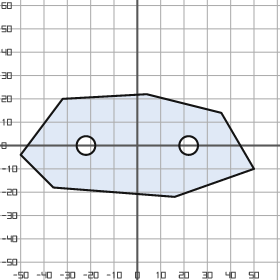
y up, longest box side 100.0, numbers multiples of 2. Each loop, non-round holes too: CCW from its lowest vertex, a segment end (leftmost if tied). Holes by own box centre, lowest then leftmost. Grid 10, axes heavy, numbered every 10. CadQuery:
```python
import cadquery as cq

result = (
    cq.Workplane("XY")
    .moveTo(16.0, -22.0)
    .lineTo(50.0, -10.0)
    .lineTo(36.0, 14.0)
    .lineTo(4.0, 22.0)
    .lineTo(-32.0, 20.0)
    .lineTo(-50.0, -4.0)
    .lineTo(-36.0, -18.0)
    .close()
    .moveTo(-22.0, 0.0)
    .circle(4.0)
    .moveTo(22.0, 0.0)
    .circle(4.0)
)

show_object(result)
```